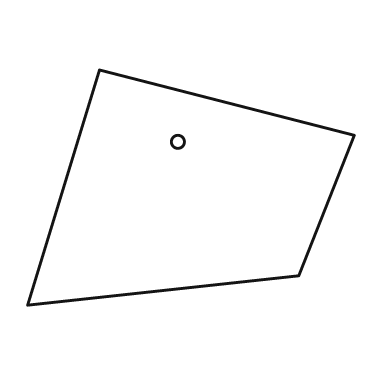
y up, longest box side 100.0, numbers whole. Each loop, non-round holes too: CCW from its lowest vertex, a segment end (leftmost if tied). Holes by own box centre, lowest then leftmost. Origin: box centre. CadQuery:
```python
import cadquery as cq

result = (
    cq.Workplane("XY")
    .moveTo(-50.0, -36.0)
    .lineTo(33.0, -27.0)
    .lineTo(50.0, 16.0)
    .lineTo(-28.0, 36.0)
    .close()
    .moveTo(-4.0, 14.0)
    .circle(2.0)
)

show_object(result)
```